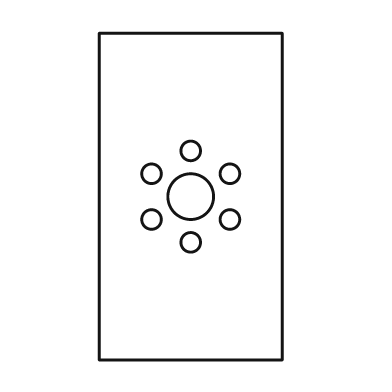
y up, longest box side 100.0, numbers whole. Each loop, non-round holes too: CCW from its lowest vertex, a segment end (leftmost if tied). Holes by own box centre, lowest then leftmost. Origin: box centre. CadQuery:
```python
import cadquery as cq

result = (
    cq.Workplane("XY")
    .moveTo(-28.0, -50.0)
    .lineTo(28.0, -50.0)
    .lineTo(28.0, 50.0)
    .lineTo(-28.0, 50.0)
    .close()
    .moveTo(0.0, -14.0)
    .circle(3.0)
    .moveTo(-12.0, -7.0)
    .circle(3.0)
    .moveTo(12.0, -7.0)
    .circle(3.0)
    .moveTo(0.0, 0.0)
    .circle(7.0)
    .moveTo(-12.0, 7.0)
    .circle(3.0)
    .moveTo(12.0, 7.0)
    .circle(3.0)
    .moveTo(0.0, 14.0)
    .circle(3.0)
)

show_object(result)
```